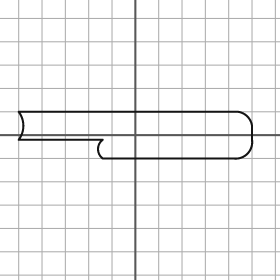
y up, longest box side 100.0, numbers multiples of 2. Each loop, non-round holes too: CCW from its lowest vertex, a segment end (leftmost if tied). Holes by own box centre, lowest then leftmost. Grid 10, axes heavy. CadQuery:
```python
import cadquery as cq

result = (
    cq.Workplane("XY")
    .moveTo(-14.0, -10.0)
    .lineTo(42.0, -10.0)
    .threePointArc((48.0, -8.0), (50.0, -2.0))
    .lineTo(50.0, 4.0)
    .threePointArc((48.0, 8.0), (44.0, 10.0))
    .lineTo(-50.0, 10.0)
    .threePointArc((-48.0, 4.0), (-50.0, -2.0))
    .lineTo(-14.0, -2.0)
    .threePointArc((-16.0, -6.0), (-14.0, -10.0))
    .close()
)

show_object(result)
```